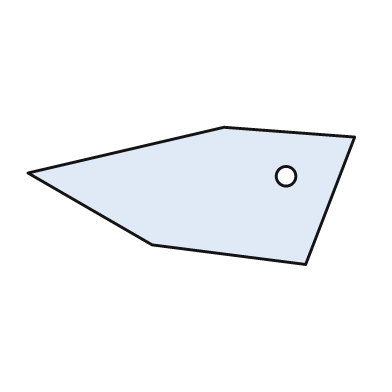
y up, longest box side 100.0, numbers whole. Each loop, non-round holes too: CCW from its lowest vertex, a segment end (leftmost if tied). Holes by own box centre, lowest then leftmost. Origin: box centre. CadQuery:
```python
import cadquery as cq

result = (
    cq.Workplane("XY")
    .moveTo(35.0, -21.0)
    .lineTo(50.0, 18.0)
    .lineTo(10.0, 21.0)
    .lineTo(-50.0, 7.0)
    .lineTo(-12.0, -15.0)
    .close()
    .moveTo(29.0, 6.0)
    .circle(3.0)
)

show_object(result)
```